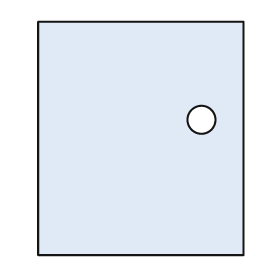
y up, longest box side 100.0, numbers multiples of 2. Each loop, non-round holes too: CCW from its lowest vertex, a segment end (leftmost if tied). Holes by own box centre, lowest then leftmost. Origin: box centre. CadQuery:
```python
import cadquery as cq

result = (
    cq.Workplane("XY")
    .moveTo(-44.0, -50.0)
    .lineTo(44.0, -50.0)
    .lineTo(44.0, 50.0)
    .lineTo(-44.0, 50.0)
    .close()
    .moveTo(26.0, 8.0)
    .circle(6.0)
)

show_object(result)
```